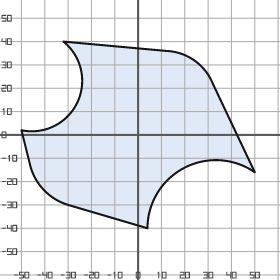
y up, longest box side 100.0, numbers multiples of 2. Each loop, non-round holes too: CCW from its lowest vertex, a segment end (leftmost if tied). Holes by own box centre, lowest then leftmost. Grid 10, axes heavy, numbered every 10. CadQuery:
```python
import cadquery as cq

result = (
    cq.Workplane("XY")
    .moveTo(4.0, -40.0)
    .threePointArc((20.0, -14.0), (50.0, -16.0))
    .lineTo(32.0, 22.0)
    .threePointArc((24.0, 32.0), (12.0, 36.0))
    .lineTo(-32.0, 40.0)
    .threePointArc((-26.0, 14.0), (-50.0, 2.0))
    .lineTo(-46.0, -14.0)
    .threePointArc((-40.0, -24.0), (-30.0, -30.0))
    .close()
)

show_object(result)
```